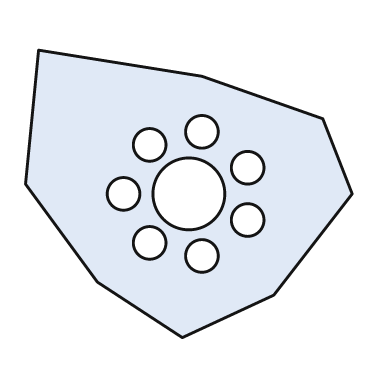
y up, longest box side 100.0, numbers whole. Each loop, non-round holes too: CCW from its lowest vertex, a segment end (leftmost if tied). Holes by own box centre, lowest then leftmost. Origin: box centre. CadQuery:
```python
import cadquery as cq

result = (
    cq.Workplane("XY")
    .moveTo(-2.0, -44.0)
    .lineTo(26.0, -31.0)
    .lineTo(50.0, 0.0)
    .lineTo(41.0, 23.0)
    .lineTo(4.0, 36.0)
    .lineTo(-46.0, 44.0)
    .lineTo(-50.0, 3.0)
    .lineTo(-28.0, -27.0)
    .close()
    .moveTo(4.0, -19.0)
    .circle(5.0)
    .moveTo(-12.0, -15.0)
    .circle(5.0)
    .moveTo(18.0, -8.0)
    .circle(5.0)
    .moveTo(-20.0, 0.0)
    .circle(5.0)
    .moveTo(0.0, 0.0)
    .circle(11.0)
    .moveTo(18.0, 8.0)
    .circle(5.0)
    .moveTo(-12.0, 15.0)
    .circle(5.0)
    .moveTo(4.0, 19.0)
    .circle(5.0)
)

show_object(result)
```